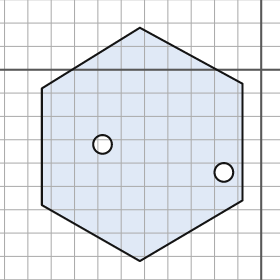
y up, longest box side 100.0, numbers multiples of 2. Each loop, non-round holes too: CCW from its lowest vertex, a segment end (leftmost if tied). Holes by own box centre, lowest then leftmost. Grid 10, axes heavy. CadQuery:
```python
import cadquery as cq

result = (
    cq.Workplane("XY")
    .moveTo(-52.0, -82.0)
    .lineTo(-8.0, -56.0)
    .lineTo(-8.0, -6.0)
    .lineTo(-52.0, 18.0)
    .lineTo(-94.0, -8.0)
    .lineTo(-94.0, -58.0)
    .close()
    .moveTo(-16.0, -44.0)
    .circle(4.0)
    .moveTo(-68.0, -32.0)
    .circle(4.0)
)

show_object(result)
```